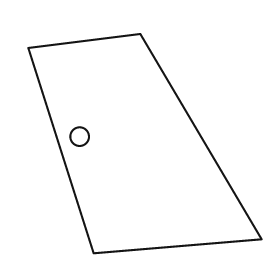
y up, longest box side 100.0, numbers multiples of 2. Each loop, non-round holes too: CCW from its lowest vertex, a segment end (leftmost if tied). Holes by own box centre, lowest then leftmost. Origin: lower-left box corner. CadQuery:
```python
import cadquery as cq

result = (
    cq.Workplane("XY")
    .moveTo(28.0, 0.0)
    .lineTo(100.0, 6.0)
    .lineTo(48.0, 94.0)
    .lineTo(0.0, 88.0)
    .close()
    .moveTo(22.0, 50.0)
    .circle(4.0)
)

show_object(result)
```